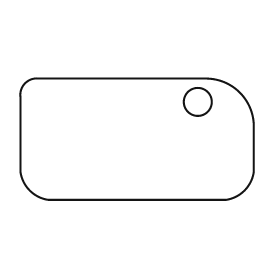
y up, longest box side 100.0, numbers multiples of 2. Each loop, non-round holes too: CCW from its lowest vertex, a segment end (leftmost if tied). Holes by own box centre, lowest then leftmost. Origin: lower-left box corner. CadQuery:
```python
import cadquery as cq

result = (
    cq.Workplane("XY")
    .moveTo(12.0, 0.0)
    .lineTo(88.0, 0.0)
    .threePointArc((96.0, 4.0), (100.0, 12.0))
    .lineTo(100.0, 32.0)
    .threePointArc((94.0, 46.0), (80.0, 52.0))
    .lineTo(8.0, 52.0)
    .threePointArc((2.0, 50.0), (0.0, 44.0))
    .lineTo(0.0, 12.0)
    .threePointArc((4.0, 4.0), (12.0, 0.0))
    .close()
    .moveTo(76.0, 42.0)
    .circle(6.0)
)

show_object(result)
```